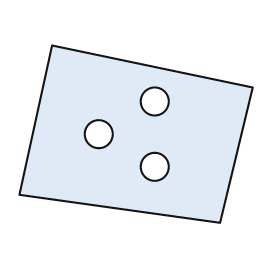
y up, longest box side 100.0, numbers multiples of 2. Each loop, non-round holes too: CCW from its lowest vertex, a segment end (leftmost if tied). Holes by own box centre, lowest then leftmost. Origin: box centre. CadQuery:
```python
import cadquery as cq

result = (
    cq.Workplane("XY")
    .moveTo(36.0, -38.0)
    .lineTo(50.0, 20.0)
    .lineTo(-36.0, 38.0)
    .lineTo(-50.0, -26.0)
    .close()
    .moveTo(8.0, -14.0)
    .circle(6.0)
    .moveTo(-16.0, 0.0)
    .circle(6.0)
    .moveTo(8.0, 14.0)
    .circle(6.0)
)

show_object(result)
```